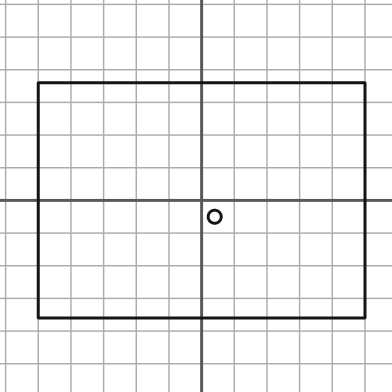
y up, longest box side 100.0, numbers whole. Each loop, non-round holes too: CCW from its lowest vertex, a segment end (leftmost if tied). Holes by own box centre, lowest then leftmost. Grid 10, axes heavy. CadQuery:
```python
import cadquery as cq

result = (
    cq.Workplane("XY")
    .moveTo(-50.0, -36.0)
    .lineTo(50.0, -36.0)
    .lineTo(50.0, 36.0)
    .lineTo(-50.0, 36.0)
    .close()
    .moveTo(4.0, -5.0)
    .circle(2.0)
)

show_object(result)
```